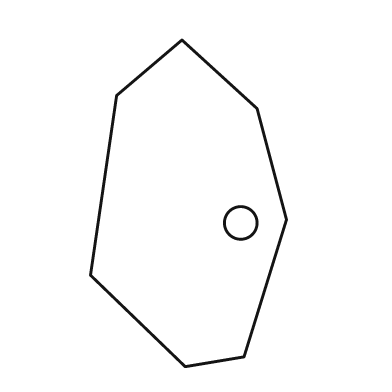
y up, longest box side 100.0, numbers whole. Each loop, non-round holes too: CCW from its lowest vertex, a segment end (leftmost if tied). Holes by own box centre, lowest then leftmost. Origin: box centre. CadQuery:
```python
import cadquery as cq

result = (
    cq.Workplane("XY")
    .moveTo(-1.0, -50.0)
    .lineTo(17.0, -47.0)
    .lineTo(30.0, -5.0)
    .lineTo(21.0, 29.0)
    .lineTo(-2.0, 50.0)
    .lineTo(-22.0, 33.0)
    .lineTo(-30.0, -22.0)
    .close()
    .moveTo(16.0, -6.0)
    .circle(5.0)
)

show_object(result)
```